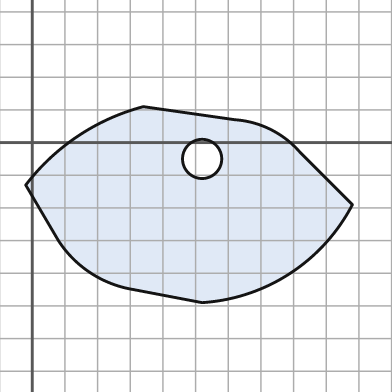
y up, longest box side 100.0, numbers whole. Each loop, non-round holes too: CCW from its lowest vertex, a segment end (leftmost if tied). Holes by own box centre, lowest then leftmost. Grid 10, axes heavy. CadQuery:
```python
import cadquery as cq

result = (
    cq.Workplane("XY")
    .moveTo(52.0, -49.0)
    .threePointArc((79.0, -40.0), (98.0, -19.0))
    .lineTo(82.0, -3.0)
    .threePointArc((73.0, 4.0), (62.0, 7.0))
    .lineTo(34.0, 11.0)
    .threePointArc((14.0, 2.0), (-2.0, -13.0))
    .lineTo(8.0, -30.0)
    .threePointArc((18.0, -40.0), (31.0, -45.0))
    .close()
    .moveTo(52.0, -5.0)
    .circle(6.0)
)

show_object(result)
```